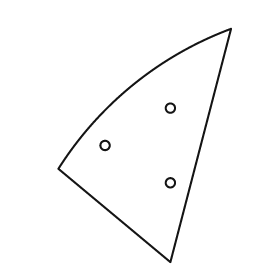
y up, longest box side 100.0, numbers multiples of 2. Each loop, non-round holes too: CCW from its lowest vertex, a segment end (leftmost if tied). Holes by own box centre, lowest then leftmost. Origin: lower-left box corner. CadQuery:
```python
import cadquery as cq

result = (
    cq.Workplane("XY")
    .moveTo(48.0, 0.0)
    .lineTo(74.0, 100.0)
    .threePointArc((32.0, 76.0), (0.0, 40.0))
    .close()
    .moveTo(48.0, 34.0)
    .circle(2.0)
    .moveTo(20.0, 50.0)
    .circle(2.0)
    .moveTo(48.0, 66.0)
    .circle(2.0)
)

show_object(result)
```